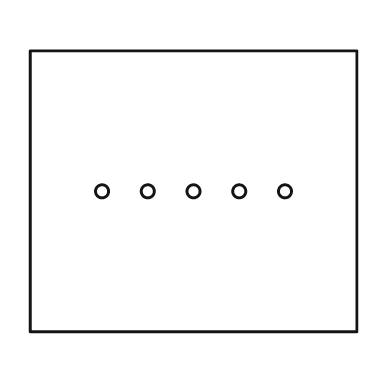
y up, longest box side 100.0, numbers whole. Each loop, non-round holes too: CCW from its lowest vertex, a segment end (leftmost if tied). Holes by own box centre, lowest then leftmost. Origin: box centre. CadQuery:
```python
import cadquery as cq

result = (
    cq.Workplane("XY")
    .moveTo(-50.0, -43.0)
    .lineTo(50.0, -43.0)
    .lineTo(50.0, 43.0)
    .lineTo(-50.0, 43.0)
    .close()
    .moveTo(-28.0, 0.0)
    .circle(2.0)
    .moveTo(-14.0, 0.0)
    .circle(2.0)
    .moveTo(0.0, 0.0)
    .circle(2.0)
    .moveTo(14.0, 0.0)
    .circle(2.0)
    .moveTo(28.0, 0.0)
    .circle(2.0)
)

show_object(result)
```